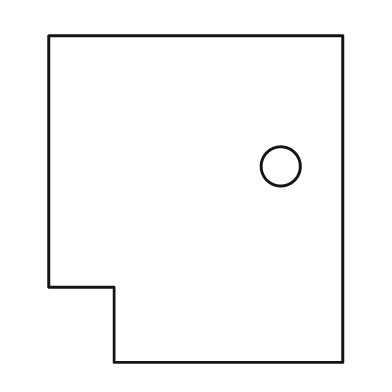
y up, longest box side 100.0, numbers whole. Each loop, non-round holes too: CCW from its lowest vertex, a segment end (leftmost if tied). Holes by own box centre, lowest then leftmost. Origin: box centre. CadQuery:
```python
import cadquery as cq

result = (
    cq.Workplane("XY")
    .moveTo(-25.0, -50.0)
    .lineTo(45.0, -50.0)
    .lineTo(45.0, 50.0)
    .lineTo(-45.0, 50.0)
    .lineTo(-45.0, -27.0)
    .lineTo(-25.0, -27.0)
    .close()
    .moveTo(26.0, 10.0)
    .circle(6.0)
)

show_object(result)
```